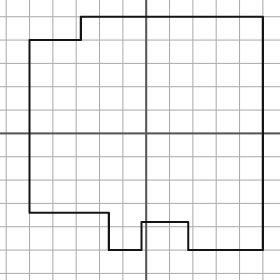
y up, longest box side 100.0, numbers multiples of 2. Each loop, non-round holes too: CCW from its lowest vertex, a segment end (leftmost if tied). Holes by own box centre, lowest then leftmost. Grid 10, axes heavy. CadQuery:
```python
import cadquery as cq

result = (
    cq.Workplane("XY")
    .moveTo(-16.0, -50.0)
    .lineTo(-2.0, -50.0)
    .lineTo(-2.0, -38.0)
    .lineTo(18.0, -38.0)
    .lineTo(18.0, -50.0)
    .lineTo(50.0, -50.0)
    .lineTo(50.0, 50.0)
    .lineTo(-28.0, 50.0)
    .lineTo(-28.0, 40.0)
    .lineTo(-50.0, 40.0)
    .lineTo(-50.0, -34.0)
    .lineTo(-16.0, -34.0)
    .close()
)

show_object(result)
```